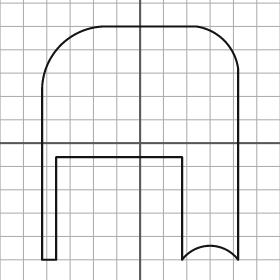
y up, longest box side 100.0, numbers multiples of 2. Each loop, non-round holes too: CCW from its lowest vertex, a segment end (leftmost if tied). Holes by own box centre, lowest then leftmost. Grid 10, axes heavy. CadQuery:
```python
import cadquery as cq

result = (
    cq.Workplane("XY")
    .moveTo(-42.0, -50.0)
    .lineTo(-36.0, -50.0)
    .lineTo(-36.0, -6.0)
    .lineTo(18.0, -6.0)
    .lineTo(18.0, -50.0)
    .threePointArc((30.0, -44.0), (42.0, -50.0))
    .lineTo(42.0, 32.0)
    .threePointArc((36.0, 44.0), (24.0, 50.0))
    .lineTo(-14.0, 50.0)
    .threePointArc((-34.0, 42.0), (-42.0, 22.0))
    .close()
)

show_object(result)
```